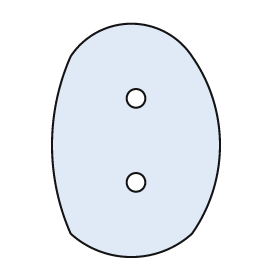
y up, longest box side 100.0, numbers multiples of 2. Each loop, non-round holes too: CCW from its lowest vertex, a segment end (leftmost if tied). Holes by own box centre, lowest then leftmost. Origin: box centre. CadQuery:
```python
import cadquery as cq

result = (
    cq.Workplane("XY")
    .moveTo(-28.0, -40.0)
    .threePointArc((-2.0, -50.0), (24.0, -40.0))
    .threePointArc((36.0, -2.0), (24.0, 36.0))
    .threePointArc((-2.0, 50.0), (-28.0, 36.0))
    .threePointArc((-36.0, -2.0), (-28.0, -40.0))
    .close()
    .moveTo(0.0, -18.0)
    .circle(4.0)
    .moveTo(0.0, 18.0)
    .circle(4.0)
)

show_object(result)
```